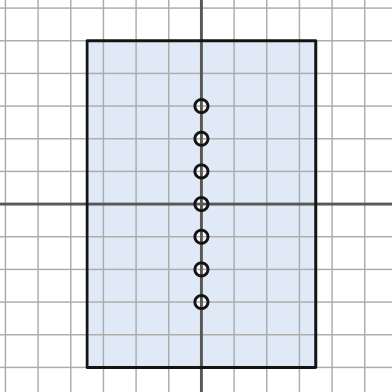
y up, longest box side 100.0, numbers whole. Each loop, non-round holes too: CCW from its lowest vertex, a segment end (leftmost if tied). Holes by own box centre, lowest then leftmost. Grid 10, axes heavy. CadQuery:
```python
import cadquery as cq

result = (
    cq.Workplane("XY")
    .moveTo(-35.0, -50.0)
    .lineTo(35.0, -50.0)
    .lineTo(35.0, 50.0)
    .lineTo(-35.0, 50.0)
    .close()
    .moveTo(0.0, -30.0)
    .circle(2.0)
    .moveTo(0.0, -20.0)
    .circle(2.0)
    .moveTo(0.0, -10.0)
    .circle(2.0)
    .moveTo(0.0, 0.0)
    .circle(2.0)
    .moveTo(0.0, 10.0)
    .circle(2.0)
    .moveTo(0.0, 20.0)
    .circle(2.0)
    .moveTo(0.0, 30.0)
    .circle(2.0)
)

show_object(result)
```